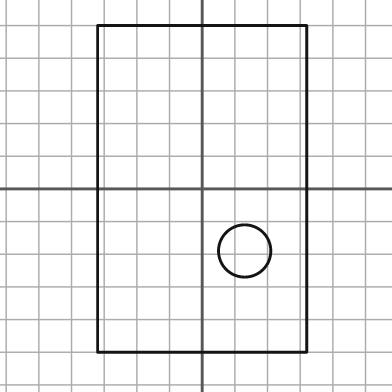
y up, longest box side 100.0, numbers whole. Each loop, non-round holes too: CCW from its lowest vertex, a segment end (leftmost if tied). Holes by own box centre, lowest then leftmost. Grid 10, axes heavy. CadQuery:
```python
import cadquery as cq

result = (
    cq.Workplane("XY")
    .moveTo(-32.0, -50.0)
    .lineTo(32.0, -50.0)
    .lineTo(32.0, 50.0)
    .lineTo(-32.0, 50.0)
    .close()
    .moveTo(13.0, -19.0)
    .circle(8.0)
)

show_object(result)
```